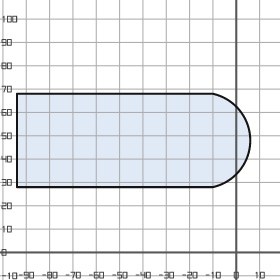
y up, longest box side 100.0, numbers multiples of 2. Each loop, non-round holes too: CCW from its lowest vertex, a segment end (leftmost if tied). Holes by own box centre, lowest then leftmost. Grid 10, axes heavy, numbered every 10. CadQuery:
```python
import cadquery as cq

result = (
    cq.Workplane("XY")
    .moveTo(-94.0, 28.0)
    .lineTo(-10.0, 28.0)
    .threePointArc((6.0, 48.0), (-10.0, 68.0))
    .lineTo(-94.0, 68.0)
    .close()
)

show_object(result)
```